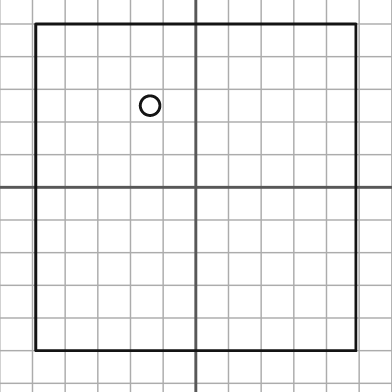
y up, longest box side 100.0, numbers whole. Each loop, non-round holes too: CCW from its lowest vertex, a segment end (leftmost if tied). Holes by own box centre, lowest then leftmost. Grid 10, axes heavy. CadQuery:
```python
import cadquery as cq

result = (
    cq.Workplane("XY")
    .moveTo(-49.0, -50.0)
    .lineTo(49.0, -50.0)
    .lineTo(49.0, 50.0)
    .lineTo(-49.0, 50.0)
    .close()
    .moveTo(-14.0, 25.0)
    .circle(3.0)
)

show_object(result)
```